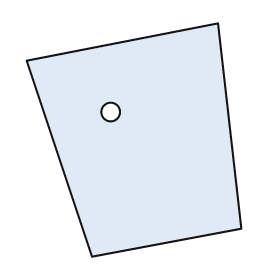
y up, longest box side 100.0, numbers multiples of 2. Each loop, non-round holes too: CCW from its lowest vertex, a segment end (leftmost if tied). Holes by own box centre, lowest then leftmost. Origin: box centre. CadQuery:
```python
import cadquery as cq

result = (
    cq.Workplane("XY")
    .moveTo(-18.0, -50.0)
    .lineTo(46.0, -38.0)
    .lineTo(36.0, 50.0)
    .lineTo(-46.0, 34.0)
    .close()
    .moveTo(-10.0, 12.0)
    .circle(4.0)
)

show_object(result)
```